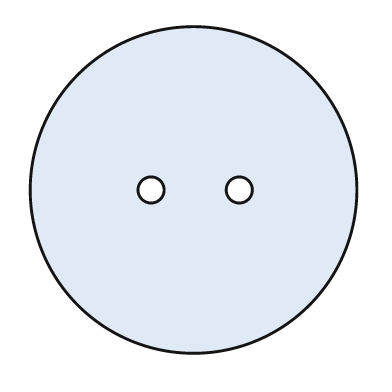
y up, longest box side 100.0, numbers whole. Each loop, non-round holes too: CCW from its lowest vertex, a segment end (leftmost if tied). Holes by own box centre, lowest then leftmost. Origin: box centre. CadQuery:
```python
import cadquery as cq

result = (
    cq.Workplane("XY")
    .moveTo(0.0, 0.0)
    .circle(50.0)
    .moveTo(-13.0, 0.0)
    .circle(4.0)
    .moveTo(14.0, 0.0)
    .circle(4.0)
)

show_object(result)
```